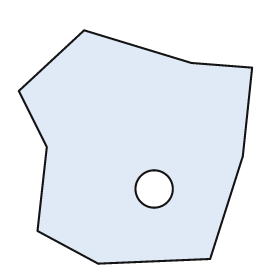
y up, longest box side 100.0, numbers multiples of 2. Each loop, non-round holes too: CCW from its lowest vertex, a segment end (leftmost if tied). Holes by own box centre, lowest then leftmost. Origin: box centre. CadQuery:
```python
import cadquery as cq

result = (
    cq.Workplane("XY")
    .moveTo(-16.0, -50.0)
    .lineTo(32.0, -48.0)
    .lineTo(46.0, -4.0)
    .lineTo(50.0, 34.0)
    .lineTo(24.0, 36.0)
    .lineTo(-22.0, 50.0)
    .lineTo(-50.0, 24.0)
    .lineTo(-38.0, 0.0)
    .lineTo(-42.0, -36.0)
    .close()
    .moveTo(8.0, -18.0)
    .circle(8.0)
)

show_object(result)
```